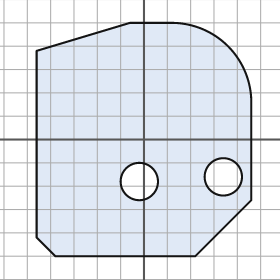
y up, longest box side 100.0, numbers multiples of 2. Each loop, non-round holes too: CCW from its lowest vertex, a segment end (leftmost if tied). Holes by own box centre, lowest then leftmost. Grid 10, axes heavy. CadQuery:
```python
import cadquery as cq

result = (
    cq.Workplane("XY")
    .moveTo(-38.0, -50.0)
    .lineTo(22.0, -50.0)
    .lineTo(46.0, -26.0)
    .lineTo(46.0, 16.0)
    .threePointArc((36.0, 40.0), (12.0, 50.0))
    .lineTo(-6.0, 50.0)
    .lineTo(-46.0, 38.0)
    .lineTo(-46.0, -42.0)
    .close()
    .moveTo(-2.0, -18.0)
    .circle(8.0)
    .moveTo(34.0, -16.0)
    .circle(8.0)
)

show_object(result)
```